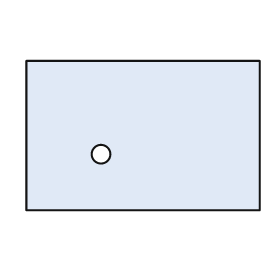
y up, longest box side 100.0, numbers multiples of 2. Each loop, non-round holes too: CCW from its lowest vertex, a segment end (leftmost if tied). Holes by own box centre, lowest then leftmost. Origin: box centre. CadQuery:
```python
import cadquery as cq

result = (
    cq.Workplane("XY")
    .moveTo(-50.0, -32.0)
    .lineTo(50.0, -32.0)
    .lineTo(50.0, 32.0)
    .lineTo(-50.0, 32.0)
    .close()
    .moveTo(-18.0, -8.0)
    .circle(4.0)
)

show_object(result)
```